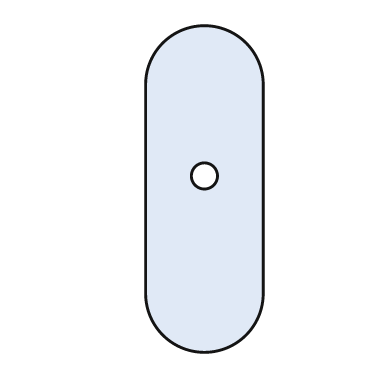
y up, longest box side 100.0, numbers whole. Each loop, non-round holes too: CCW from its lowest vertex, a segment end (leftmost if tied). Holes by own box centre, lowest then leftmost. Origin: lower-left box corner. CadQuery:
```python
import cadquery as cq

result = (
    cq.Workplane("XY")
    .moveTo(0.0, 18.0)
    .threePointArc((18.0, 0.0), (36.0, 18.0))
    .lineTo(36.0, 82.0)
    .threePointArc((18.0, 100.0), (0.0, 82.0))
    .close()
    .moveTo(18.0, 54.0)
    .circle(4.0)
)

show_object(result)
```